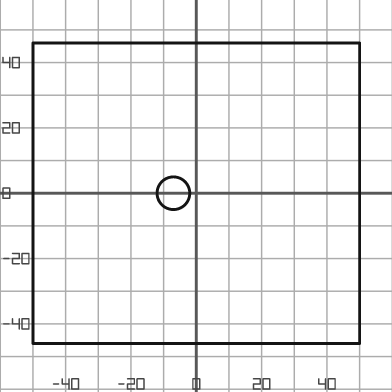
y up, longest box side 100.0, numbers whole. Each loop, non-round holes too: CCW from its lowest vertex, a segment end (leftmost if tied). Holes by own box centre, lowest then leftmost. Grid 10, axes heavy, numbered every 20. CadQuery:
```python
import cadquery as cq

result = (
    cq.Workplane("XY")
    .moveTo(-50.0, -46.0)
    .lineTo(50.0, -46.0)
    .lineTo(50.0, 46.0)
    .lineTo(-50.0, 46.0)
    .close()
    .moveTo(-7.0, 0.0)
    .circle(5.0)
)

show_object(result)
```